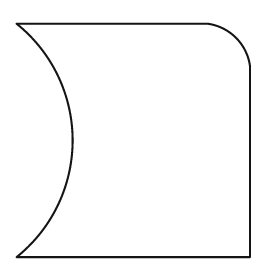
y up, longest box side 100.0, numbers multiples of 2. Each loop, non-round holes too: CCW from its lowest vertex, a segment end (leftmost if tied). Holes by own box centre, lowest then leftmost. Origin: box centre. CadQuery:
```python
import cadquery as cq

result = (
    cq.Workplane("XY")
    .moveTo(-50.0, -50.0)
    .lineTo(50.0, -50.0)
    .lineTo(50.0, 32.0)
    .threePointArc((44.0, 44.0), (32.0, 50.0))
    .lineTo(-50.0, 50.0)
    .threePointArc((-26.0, 0.0), (-50.0, -50.0))
    .close()
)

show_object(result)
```